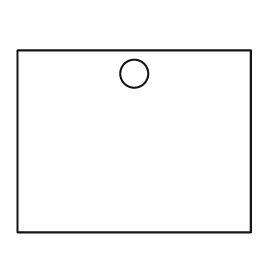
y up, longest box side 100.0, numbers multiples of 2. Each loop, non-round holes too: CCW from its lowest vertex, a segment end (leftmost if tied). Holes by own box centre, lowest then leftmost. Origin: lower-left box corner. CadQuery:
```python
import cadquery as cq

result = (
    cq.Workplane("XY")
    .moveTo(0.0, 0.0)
    .lineTo(100.0, 0.0)
    .lineTo(100.0, 78.0)
    .lineTo(0.0, 78.0)
    .close()
    .moveTo(50.0, 68.0)
    .circle(6.0)
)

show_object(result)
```